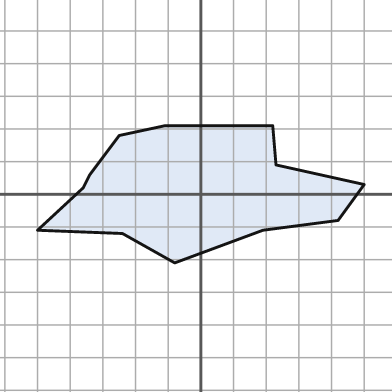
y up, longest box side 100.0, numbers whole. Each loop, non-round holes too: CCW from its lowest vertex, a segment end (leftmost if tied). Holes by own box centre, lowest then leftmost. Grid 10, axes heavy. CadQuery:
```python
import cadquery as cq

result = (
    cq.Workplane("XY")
    .moveTo(-8.0, -21.0)
    .lineTo(19.0, -11.0)
    .lineTo(42.0, -8.0)
    .lineTo(50.0, 3.0)
    .lineTo(23.0, 9.0)
    .lineTo(22.0, 21.0)
    .lineTo(-11.0, 21.0)
    .lineTo(-25.0, 18.0)
    .lineTo(-34.0, 6.0)
    .lineTo(-36.0, 2.0)
    .lineTo(-50.0, -11.0)
    .lineTo(-24.0, -12.0)
    .close()
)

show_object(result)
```